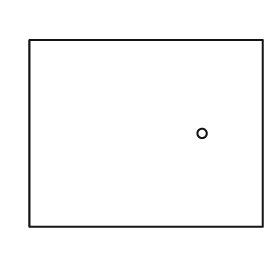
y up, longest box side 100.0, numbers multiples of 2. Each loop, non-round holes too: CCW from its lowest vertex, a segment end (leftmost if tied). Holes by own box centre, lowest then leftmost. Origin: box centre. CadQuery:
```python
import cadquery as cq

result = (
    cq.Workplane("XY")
    .moveTo(-50.0, -40.0)
    .lineTo(50.0, -40.0)
    .lineTo(50.0, 40.0)
    .lineTo(-50.0, 40.0)
    .close()
    .moveTo(24.0, 0.0)
    .circle(2.0)
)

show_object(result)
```